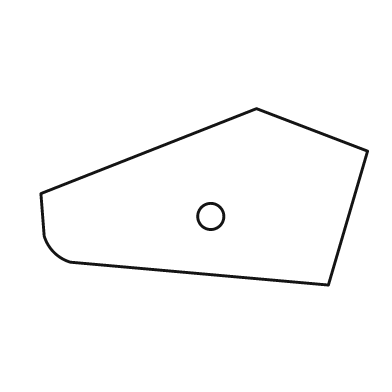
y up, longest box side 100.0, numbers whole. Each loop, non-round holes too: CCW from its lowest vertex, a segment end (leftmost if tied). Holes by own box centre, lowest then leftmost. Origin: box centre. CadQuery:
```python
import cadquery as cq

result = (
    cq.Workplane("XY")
    .moveTo(38.0, -27.0)
    .lineTo(50.0, 14.0)
    .lineTo(16.0, 27.0)
    .lineTo(-50.0, 1.0)
    .lineTo(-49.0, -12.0)
    .threePointArc((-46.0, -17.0), (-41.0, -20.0))
    .close()
    .moveTo(2.0, -6.0)
    .circle(4.0)
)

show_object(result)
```